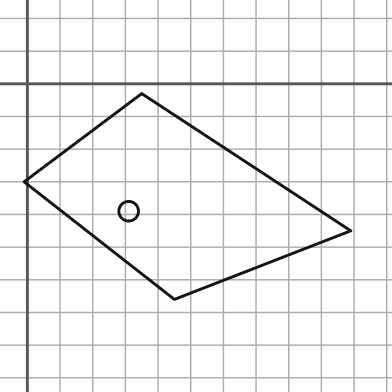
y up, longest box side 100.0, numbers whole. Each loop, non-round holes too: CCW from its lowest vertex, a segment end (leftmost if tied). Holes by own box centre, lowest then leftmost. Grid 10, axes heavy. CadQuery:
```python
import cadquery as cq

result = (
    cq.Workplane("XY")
    .moveTo(45.0, -66.0)
    .lineTo(99.0, -45.0)
    .lineTo(35.0, -3.0)
    .lineTo(-1.0, -30.0)
    .close()
    .moveTo(31.0, -39.0)
    .circle(3.0)
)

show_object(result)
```